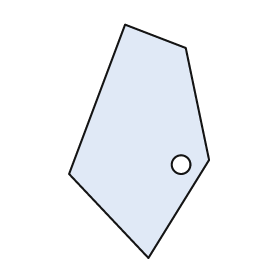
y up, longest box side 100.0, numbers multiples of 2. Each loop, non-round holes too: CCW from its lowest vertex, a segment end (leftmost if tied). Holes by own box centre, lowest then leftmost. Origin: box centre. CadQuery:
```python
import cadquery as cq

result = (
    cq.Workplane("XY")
    .moveTo(4.0, -50.0)
    .lineTo(30.0, -8.0)
    .lineTo(20.0, 40.0)
    .lineTo(-6.0, 50.0)
    .lineTo(-30.0, -14.0)
    .close()
    .moveTo(18.0, -10.0)
    .circle(4.0)
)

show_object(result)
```